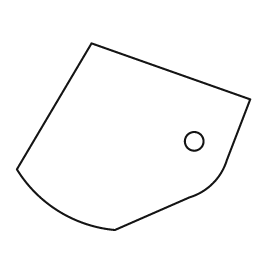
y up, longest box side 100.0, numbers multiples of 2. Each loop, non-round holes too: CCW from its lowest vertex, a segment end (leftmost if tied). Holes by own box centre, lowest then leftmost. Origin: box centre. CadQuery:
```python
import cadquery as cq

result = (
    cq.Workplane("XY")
    .moveTo(-8.0, -40.0)
    .lineTo(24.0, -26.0)
    .threePointArc((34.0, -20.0), (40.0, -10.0))
    .lineTo(50.0, 16.0)
    .lineTo(-18.0, 40.0)
    .lineTo(-50.0, -14.0)
    .threePointArc((-32.0, -32.0), (-8.0, -40.0))
    .close()
    .moveTo(26.0, -2.0)
    .circle(4.0)
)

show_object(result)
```